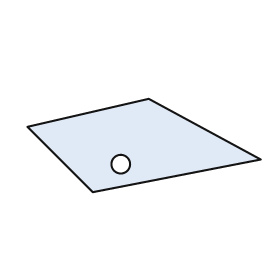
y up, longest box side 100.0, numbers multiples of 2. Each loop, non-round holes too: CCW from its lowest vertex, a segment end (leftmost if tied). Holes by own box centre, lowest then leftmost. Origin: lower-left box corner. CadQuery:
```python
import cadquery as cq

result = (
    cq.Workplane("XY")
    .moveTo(28.0, 0.0)
    .lineTo(100.0, 14.0)
    .lineTo(52.0, 40.0)
    .lineTo(0.0, 28.0)
    .close()
    .moveTo(40.0, 12.0)
    .circle(4.0)
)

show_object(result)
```